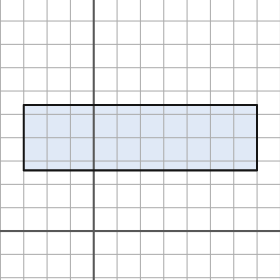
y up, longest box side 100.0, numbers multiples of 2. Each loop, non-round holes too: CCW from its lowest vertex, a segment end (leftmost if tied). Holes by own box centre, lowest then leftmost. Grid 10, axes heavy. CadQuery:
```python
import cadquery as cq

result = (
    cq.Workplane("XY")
    .moveTo(-30.0, 26.0)
    .lineTo(70.0, 26.0)
    .lineTo(70.0, 54.0)
    .lineTo(-30.0, 54.0)
    .close()
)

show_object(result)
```